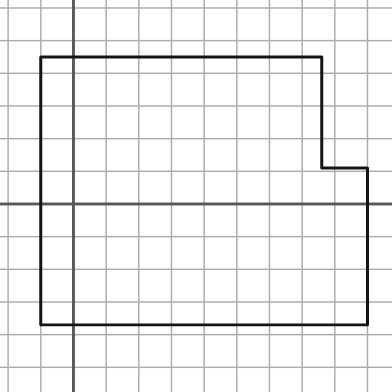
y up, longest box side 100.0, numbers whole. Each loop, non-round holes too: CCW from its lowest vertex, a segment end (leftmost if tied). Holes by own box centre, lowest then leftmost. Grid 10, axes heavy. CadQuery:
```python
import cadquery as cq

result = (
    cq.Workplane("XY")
    .moveTo(-10.0, -37.0)
    .lineTo(90.0, -37.0)
    .lineTo(90.0, 11.0)
    .lineTo(76.0, 11.0)
    .lineTo(76.0, 45.0)
    .lineTo(-10.0, 45.0)
    .close()
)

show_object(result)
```